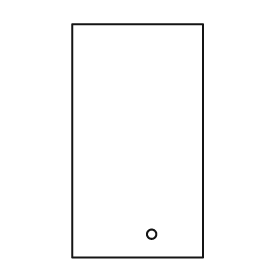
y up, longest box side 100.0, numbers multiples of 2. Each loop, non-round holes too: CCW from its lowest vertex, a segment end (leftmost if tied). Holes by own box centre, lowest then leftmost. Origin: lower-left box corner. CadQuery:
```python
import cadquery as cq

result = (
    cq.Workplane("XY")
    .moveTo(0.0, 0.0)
    .lineTo(56.0, 0.0)
    .lineTo(56.0, 100.0)
    .lineTo(0.0, 100.0)
    .close()
    .moveTo(34.0, 10.0)
    .circle(2.0)
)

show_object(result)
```